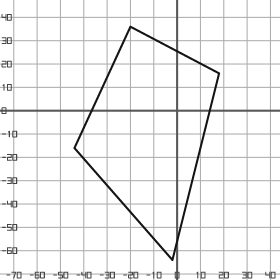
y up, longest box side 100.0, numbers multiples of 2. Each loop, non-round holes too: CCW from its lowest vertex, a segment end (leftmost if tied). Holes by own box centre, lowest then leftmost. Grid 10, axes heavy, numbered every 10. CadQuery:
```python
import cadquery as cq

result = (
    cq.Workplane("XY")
    .moveTo(-2.0, -64.0)
    .lineTo(18.0, 16.0)
    .lineTo(-20.0, 36.0)
    .lineTo(-44.0, -16.0)
    .close()
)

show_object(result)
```